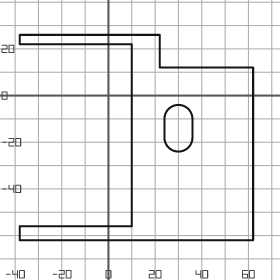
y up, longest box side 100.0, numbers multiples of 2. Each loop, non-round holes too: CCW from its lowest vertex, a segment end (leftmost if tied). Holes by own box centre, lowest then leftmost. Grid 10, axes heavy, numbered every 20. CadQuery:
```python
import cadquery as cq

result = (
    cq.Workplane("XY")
    .moveTo(-38.0, -62.0)
    .lineTo(62.0, -62.0)
    .lineTo(62.0, 12.0)
    .lineTo(22.0, 12.0)
    .lineTo(22.0, 26.0)
    .lineTo(-38.0, 26.0)
    .lineTo(-38.0, 22.0)
    .lineTo(10.0, 22.0)
    .lineTo(10.0, -56.0)
    .lineTo(-38.0, -56.0)
    .close()
    .moveTo(24.0, -18.0)
    .threePointArc((30.0, -24.0), (36.0, -18.0))
    .lineTo(36.0, -10.0)
    .threePointArc((30.0, -4.0), (24.0, -10.0))
    .close()
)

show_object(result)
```